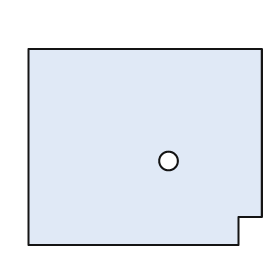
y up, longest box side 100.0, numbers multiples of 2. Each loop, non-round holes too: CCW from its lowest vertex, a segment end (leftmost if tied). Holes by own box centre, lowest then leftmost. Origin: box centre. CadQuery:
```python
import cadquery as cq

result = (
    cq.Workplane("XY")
    .moveTo(-50.0, -42.0)
    .lineTo(40.0, -42.0)
    .lineTo(40.0, -30.0)
    .lineTo(50.0, -30.0)
    .lineTo(50.0, 42.0)
    .lineTo(-50.0, 42.0)
    .close()
    .moveTo(10.0, -6.0)
    .circle(4.0)
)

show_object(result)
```